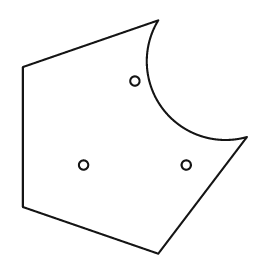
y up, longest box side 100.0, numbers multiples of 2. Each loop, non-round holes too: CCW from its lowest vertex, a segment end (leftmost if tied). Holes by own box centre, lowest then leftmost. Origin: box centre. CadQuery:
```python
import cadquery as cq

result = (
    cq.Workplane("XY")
    .moveTo(10.0, -50.0)
    .lineTo(48.0, 0.0)
    .threePointArc((12.0, 12.0), (10.0, 50.0))
    .lineTo(-48.0, 30.0)
    .lineTo(-48.0, -30.0)
    .close()
    .moveTo(-22.0, -12.0)
    .circle(2.0)
    .moveTo(22.0, -12.0)
    .circle(2.0)
    .moveTo(0.0, 24.0)
    .circle(2.0)
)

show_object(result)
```